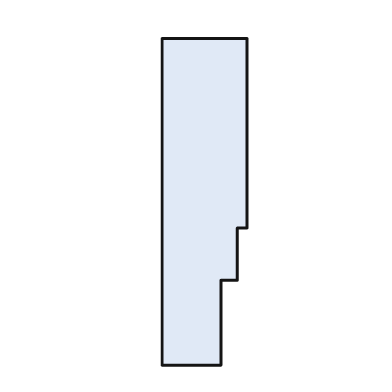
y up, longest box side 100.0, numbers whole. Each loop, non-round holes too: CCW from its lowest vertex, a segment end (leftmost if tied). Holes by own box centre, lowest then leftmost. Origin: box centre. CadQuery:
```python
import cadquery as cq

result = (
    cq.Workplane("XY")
    .moveTo(-13.0, -50.0)
    .lineTo(5.0, -50.0)
    .lineTo(5.0, -24.0)
    .lineTo(10.0, -24.0)
    .lineTo(10.0, -8.0)
    .lineTo(13.0, -8.0)
    .lineTo(13.0, 50.0)
    .lineTo(-13.0, 50.0)
    .close()
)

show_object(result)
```